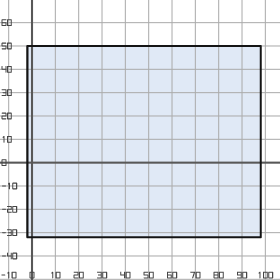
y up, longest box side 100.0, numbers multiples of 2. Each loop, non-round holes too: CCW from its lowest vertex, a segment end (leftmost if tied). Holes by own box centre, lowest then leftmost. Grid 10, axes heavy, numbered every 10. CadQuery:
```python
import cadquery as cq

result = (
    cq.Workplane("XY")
    .moveTo(-2.0, -32.0)
    .lineTo(98.0, -32.0)
    .lineTo(98.0, 50.0)
    .lineTo(-2.0, 50.0)
    .close()
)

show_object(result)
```